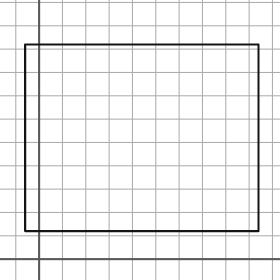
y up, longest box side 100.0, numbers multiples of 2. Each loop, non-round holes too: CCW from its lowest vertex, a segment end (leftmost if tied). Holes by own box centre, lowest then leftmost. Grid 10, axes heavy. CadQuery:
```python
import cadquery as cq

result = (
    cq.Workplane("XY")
    .moveTo(-6.0, 12.0)
    .lineTo(94.0, 12.0)
    .lineTo(94.0, 92.0)
    .lineTo(-6.0, 92.0)
    .close()
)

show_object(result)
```